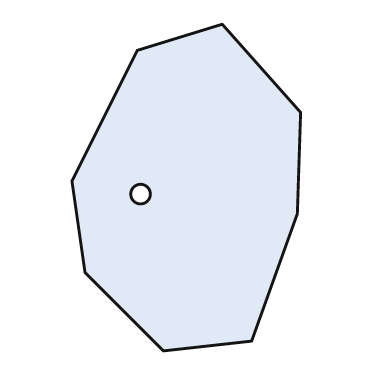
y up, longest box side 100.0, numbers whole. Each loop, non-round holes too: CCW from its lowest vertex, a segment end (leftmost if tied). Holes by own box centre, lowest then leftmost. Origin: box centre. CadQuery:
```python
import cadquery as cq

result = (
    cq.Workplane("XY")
    .moveTo(-7.0, -50.0)
    .lineTo(20.0, -47.0)
    .lineTo(34.0, -8.0)
    .lineTo(35.0, 23.0)
    .lineTo(11.0, 50.0)
    .lineTo(-15.0, 42.0)
    .lineTo(-35.0, 2.0)
    .lineTo(-31.0, -26.0)
    .close()
    .moveTo(-14.0, -2.0)
    .circle(3.0)
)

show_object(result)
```